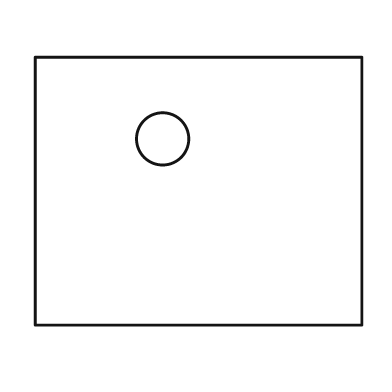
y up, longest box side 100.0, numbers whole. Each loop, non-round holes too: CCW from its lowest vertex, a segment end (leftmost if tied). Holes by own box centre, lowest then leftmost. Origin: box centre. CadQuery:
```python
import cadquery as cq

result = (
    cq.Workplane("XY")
    .moveTo(-50.0, -41.0)
    .lineTo(50.0, -41.0)
    .lineTo(50.0, 41.0)
    .lineTo(-50.0, 41.0)
    .close()
    .moveTo(-11.0, 16.0)
    .circle(8.0)
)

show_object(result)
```